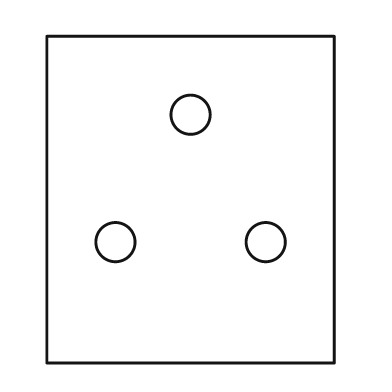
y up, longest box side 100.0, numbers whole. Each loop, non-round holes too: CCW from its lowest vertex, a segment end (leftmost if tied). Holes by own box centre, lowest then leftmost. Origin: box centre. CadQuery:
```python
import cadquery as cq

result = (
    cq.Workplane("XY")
    .moveTo(-44.0, -50.0)
    .lineTo(44.0, -50.0)
    .lineTo(44.0, 50.0)
    .lineTo(-44.0, 50.0)
    .close()
    .moveTo(-23.0, -13.0)
    .circle(6.0)
    .moveTo(23.0, -13.0)
    .circle(6.0)
    .moveTo(0.0, 26.0)
    .circle(6.0)
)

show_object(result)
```